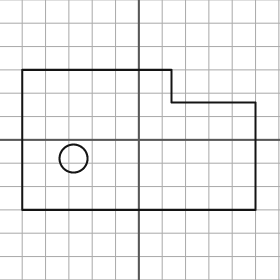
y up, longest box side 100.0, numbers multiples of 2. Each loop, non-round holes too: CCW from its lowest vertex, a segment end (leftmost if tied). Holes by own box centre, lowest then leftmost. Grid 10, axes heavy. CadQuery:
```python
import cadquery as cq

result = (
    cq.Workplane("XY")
    .moveTo(-50.0, -30.0)
    .lineTo(50.0, -30.0)
    .lineTo(50.0, 16.0)
    .lineTo(14.0, 16.0)
    .lineTo(14.0, 30.0)
    .lineTo(-50.0, 30.0)
    .close()
    .moveTo(-28.0, -8.0)
    .circle(6.0)
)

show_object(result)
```